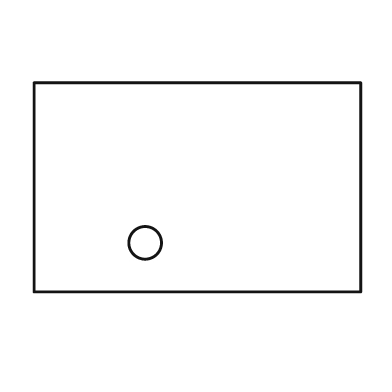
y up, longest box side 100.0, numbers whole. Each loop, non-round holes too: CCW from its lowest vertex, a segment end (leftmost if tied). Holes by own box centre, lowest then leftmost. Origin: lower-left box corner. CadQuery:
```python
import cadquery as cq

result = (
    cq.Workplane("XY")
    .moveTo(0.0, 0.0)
    .lineTo(100.0, 0.0)
    .lineTo(100.0, 64.0)
    .lineTo(0.0, 64.0)
    .close()
    .moveTo(34.0, 15.0)
    .circle(5.0)
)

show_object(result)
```